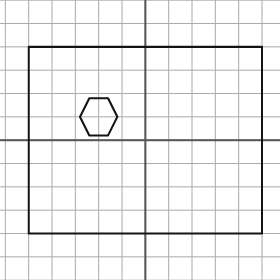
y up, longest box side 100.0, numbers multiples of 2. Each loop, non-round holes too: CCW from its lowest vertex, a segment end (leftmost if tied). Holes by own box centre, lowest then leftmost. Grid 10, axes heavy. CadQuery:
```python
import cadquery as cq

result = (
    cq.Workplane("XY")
    .moveTo(-50.0, -40.0)
    .lineTo(50.0, -40.0)
    .lineTo(50.0, 40.0)
    .lineTo(-50.0, 40.0)
    .close()
    .moveTo(-24.0, 2.0)
    .lineTo(-16.0, 2.0)
    .lineTo(-12.0, 10.0)
    .lineTo(-16.0, 18.0)
    .lineTo(-24.0, 18.0)
    .lineTo(-28.0, 10.0)
    .close()
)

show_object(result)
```